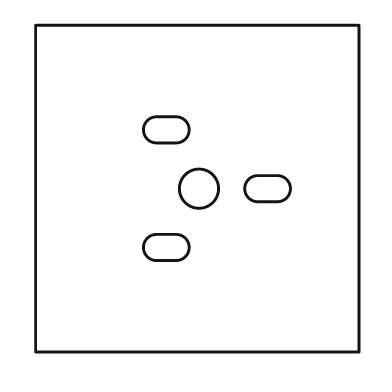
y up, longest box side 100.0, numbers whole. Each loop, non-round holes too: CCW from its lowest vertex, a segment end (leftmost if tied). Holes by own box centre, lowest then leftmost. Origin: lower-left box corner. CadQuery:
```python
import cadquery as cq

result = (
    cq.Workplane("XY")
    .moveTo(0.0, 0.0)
    .lineTo(99.0, 0.0)
    .lineTo(99.0, 100.0)
    .lineTo(0.0, 100.0)
    .close()
    .moveTo(37.0, 28.0)
    .lineTo(43.0, 28.0)
    .threePointArc((47.0, 32.0), (43.0, 36.0))
    .lineTo(37.0, 36.0)
    .threePointArc((33.0, 32.0), (37.0, 28.0))
    .close()
    .moveTo(50.0, 50.0)
    .circle(6.0)
    .moveTo(68.0, 46.0)
    .lineTo(74.0, 46.0)
    .threePointArc((78.0, 50.0), (74.0, 54.0))
    .lineTo(68.0, 54.0)
    .threePointArc((64.0, 50.0), (68.0, 46.0))
    .close()
    .moveTo(37.0, 64.0)
    .lineTo(43.0, 64.0)
    .threePointArc((47.0, 68.0), (43.0, 72.0))
    .lineTo(37.0, 72.0)
    .threePointArc((33.0, 68.0), (37.0, 64.0))
    .close()
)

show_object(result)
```